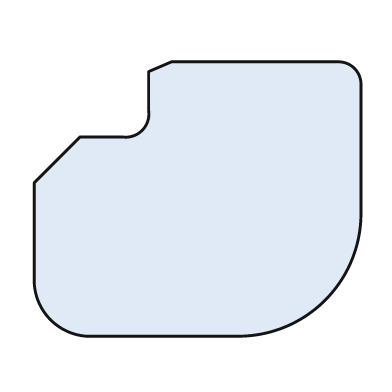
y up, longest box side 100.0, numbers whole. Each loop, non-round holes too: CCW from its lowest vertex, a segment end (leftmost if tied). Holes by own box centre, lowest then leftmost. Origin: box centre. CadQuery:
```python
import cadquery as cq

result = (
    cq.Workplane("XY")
    .moveTo(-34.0, -42.0)
    .lineTo(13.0, -42.0)
    .threePointArc((39.0, -31.0), (50.0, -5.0))
    .lineTo(50.0, 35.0)
    .threePointArc((48.0, 40.0), (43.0, 42.0))
    .lineTo(-8.0, 42.0)
    .lineTo(-15.0, 39.0)
    .lineTo(-15.0, 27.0)
    .threePointArc((-17.0, 21.0), (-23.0, 19.0))
    .lineTo(-36.0, 19.0)
    .lineTo(-50.0, 5.0)
    .lineTo(-50.0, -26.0)
    .threePointArc((-45.0, -37.0), (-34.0, -42.0))
    .close()
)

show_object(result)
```